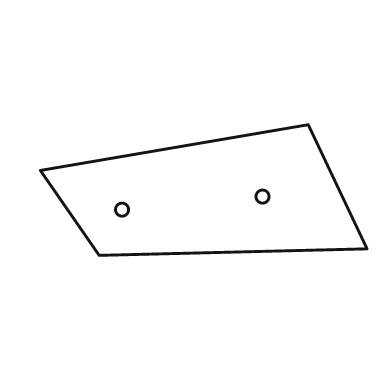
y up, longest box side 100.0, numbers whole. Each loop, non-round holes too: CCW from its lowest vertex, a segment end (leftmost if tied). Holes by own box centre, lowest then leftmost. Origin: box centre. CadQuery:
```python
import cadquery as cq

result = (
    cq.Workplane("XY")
    .moveTo(-32.0, -20.0)
    .lineTo(50.0, -18.0)
    .lineTo(32.0, 20.0)
    .lineTo(-50.0, 6.0)
    .close()
    .moveTo(-25.0, -6.0)
    .circle(2.0)
    .moveTo(18.0, -2.0)
    .circle(2.0)
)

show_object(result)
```